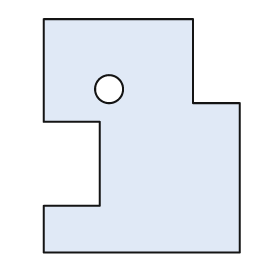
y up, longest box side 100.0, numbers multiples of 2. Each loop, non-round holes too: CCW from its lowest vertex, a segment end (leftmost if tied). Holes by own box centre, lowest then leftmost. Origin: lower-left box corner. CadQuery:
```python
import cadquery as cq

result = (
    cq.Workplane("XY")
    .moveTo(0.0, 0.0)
    .lineTo(84.0, 0.0)
    .lineTo(84.0, 64.0)
    .lineTo(64.0, 64.0)
    .lineTo(64.0, 100.0)
    .lineTo(0.0, 100.0)
    .lineTo(0.0, 56.0)
    .lineTo(24.0, 56.0)
    .lineTo(24.0, 20.0)
    .lineTo(0.0, 20.0)
    .close()
    .moveTo(28.0, 70.0)
    .circle(6.0)
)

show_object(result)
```